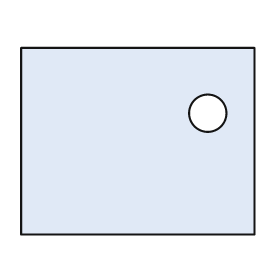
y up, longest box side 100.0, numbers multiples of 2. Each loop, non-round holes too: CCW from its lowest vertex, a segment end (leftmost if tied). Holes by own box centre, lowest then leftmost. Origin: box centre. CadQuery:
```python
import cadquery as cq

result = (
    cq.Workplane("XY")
    .moveTo(-50.0, -40.0)
    .lineTo(50.0, -40.0)
    .lineTo(50.0, 40.0)
    .lineTo(-50.0, 40.0)
    .close()
    .moveTo(30.0, 12.0)
    .circle(8.0)
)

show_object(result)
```